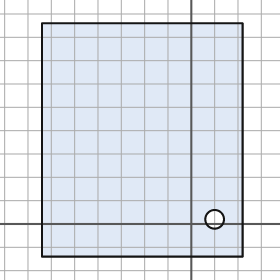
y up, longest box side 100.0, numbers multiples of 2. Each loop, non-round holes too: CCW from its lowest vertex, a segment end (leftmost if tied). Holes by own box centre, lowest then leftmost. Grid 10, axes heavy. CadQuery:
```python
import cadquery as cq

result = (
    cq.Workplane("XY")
    .moveTo(-64.0, -14.0)
    .lineTo(22.0, -14.0)
    .lineTo(22.0, 86.0)
    .lineTo(-64.0, 86.0)
    .close()
    .moveTo(10.0, 2.0)
    .circle(4.0)
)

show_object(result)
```